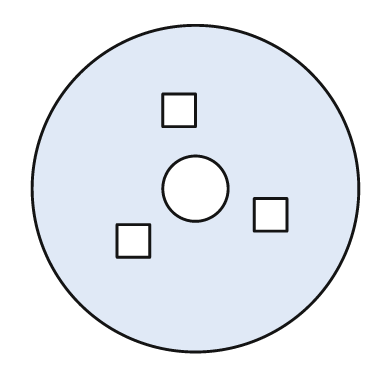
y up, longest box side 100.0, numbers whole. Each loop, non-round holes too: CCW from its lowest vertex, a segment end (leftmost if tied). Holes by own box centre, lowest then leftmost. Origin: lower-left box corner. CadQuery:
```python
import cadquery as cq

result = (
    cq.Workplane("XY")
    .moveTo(50.0, 50.0)
    .circle(50.0)
    .moveTo(26.0, 29.0)
    .lineTo(36.0, 29.0)
    .lineTo(36.0, 39.0)
    .lineTo(26.0, 39.0)
    .close()
    .moveTo(68.0, 37.0)
    .lineTo(78.0, 37.0)
    .lineTo(78.0, 47.0)
    .lineTo(68.0, 47.0)
    .close()
    .moveTo(50.0, 50.0)
    .circle(10.0)
    .moveTo(40.0, 69.0)
    .lineTo(50.0, 69.0)
    .lineTo(50.0, 79.0)
    .lineTo(40.0, 79.0)
    .close()
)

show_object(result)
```